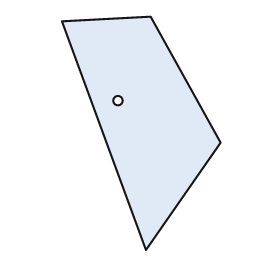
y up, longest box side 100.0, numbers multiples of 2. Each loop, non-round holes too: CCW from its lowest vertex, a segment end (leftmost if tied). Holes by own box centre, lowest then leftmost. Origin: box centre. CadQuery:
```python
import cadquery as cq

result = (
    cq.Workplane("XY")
    .moveTo(2.0, -50.0)
    .lineTo(34.0, -4.0)
    .lineTo(4.0, 50.0)
    .lineTo(-34.0, 48.0)
    .close()
    .moveTo(-10.0, 14.0)
    .circle(2.0)
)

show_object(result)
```